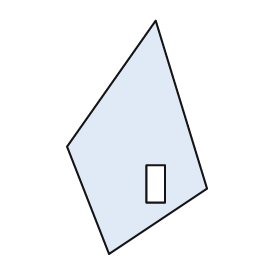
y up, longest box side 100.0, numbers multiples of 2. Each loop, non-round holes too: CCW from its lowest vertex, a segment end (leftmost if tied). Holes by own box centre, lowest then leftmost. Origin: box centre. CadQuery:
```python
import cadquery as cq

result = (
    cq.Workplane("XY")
    .moveTo(-12.0, -50.0)
    .lineTo(30.0, -22.0)
    .lineTo(8.0, 50.0)
    .lineTo(-30.0, -4.0)
    .close()
    .moveTo(4.0, -28.0)
    .lineTo(12.0, -28.0)
    .lineTo(12.0, -12.0)
    .lineTo(4.0, -12.0)
    .close()
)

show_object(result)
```